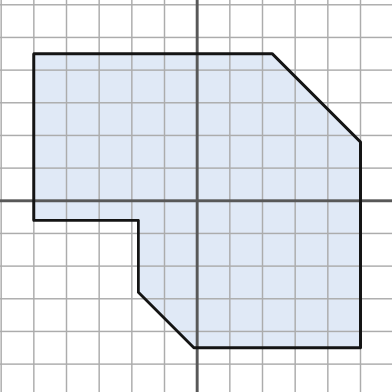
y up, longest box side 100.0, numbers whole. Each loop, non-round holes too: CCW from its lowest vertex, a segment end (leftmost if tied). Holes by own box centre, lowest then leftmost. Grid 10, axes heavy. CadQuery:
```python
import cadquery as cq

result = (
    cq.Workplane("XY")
    .moveTo(-1.0, -45.0)
    .lineTo(50.0, -45.0)
    .lineTo(50.0, 18.0)
    .lineTo(23.0, 45.0)
    .lineTo(-50.0, 45.0)
    .lineTo(-50.0, -6.0)
    .lineTo(-18.0, -6.0)
    .lineTo(-18.0, -28.0)
    .close()
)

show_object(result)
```